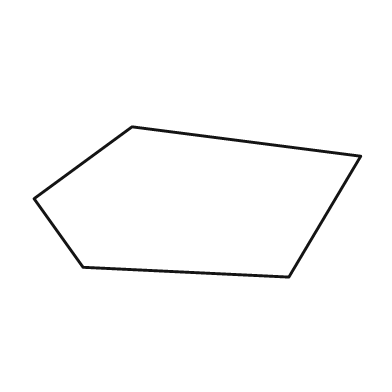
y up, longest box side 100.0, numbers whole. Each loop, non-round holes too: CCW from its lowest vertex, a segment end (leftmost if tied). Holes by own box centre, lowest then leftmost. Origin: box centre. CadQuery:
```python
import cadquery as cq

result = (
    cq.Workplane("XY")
    .moveTo(28.0, -23.0)
    .lineTo(50.0, 14.0)
    .lineTo(-20.0, 23.0)
    .lineTo(-50.0, 1.0)
    .lineTo(-35.0, -20.0)
    .close()
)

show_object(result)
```